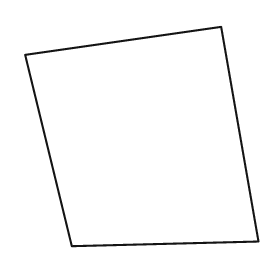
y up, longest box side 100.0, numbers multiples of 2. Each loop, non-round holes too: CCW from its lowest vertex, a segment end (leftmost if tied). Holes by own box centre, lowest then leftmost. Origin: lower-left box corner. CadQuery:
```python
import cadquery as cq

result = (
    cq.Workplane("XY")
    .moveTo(20.0, 0.0)
    .lineTo(100.0, 2.0)
    .lineTo(84.0, 94.0)
    .lineTo(0.0, 82.0)
    .close()
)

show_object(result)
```